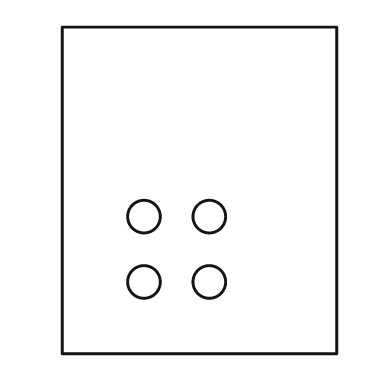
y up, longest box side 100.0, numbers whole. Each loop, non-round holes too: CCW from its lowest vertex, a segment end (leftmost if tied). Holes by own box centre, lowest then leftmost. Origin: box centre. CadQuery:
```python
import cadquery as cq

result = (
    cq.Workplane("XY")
    .moveTo(-42.0, -50.0)
    .lineTo(42.0, -50.0)
    .lineTo(42.0, 50.0)
    .lineTo(-42.0, 50.0)
    .close()
    .moveTo(-17.0, -28.0)
    .circle(5.0)
    .moveTo(3.0, -28.0)
    .circle(5.0)
    .moveTo(-17.0, -8.0)
    .circle(5.0)
    .moveTo(3.0, -8.0)
    .circle(5.0)
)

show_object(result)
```